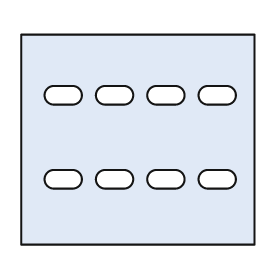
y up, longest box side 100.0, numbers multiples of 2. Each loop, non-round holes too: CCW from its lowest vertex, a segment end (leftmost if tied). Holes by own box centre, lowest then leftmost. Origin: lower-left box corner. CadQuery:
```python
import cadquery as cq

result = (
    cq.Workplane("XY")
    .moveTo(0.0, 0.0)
    .lineTo(100.0, 0.0)
    .lineTo(100.0, 90.0)
    .lineTo(0.0, 90.0)
    .close()
    .moveTo(14.0, 24.0)
    .lineTo(22.0, 24.0)
    .threePointArc((26.0, 28.0), (22.0, 32.0))
    .lineTo(14.0, 32.0)
    .threePointArc((10.0, 28.0), (14.0, 24.0))
    .close()
    .moveTo(36.0, 24.0)
    .lineTo(44.0, 24.0)
    .threePointArc((48.0, 28.0), (44.0, 32.0))
    .lineTo(36.0, 32.0)
    .threePointArc((32.0, 28.0), (36.0, 24.0))
    .close()
    .moveTo(58.0, 24.0)
    .lineTo(66.0, 24.0)
    .threePointArc((70.0, 28.0), (66.0, 32.0))
    .lineTo(58.0, 32.0)
    .threePointArc((54.0, 28.0), (58.0, 24.0))
    .close()
    .moveTo(80.0, 24.0)
    .lineTo(88.0, 24.0)
    .threePointArc((92.0, 28.0), (88.0, 32.0))
    .lineTo(80.0, 32.0)
    .threePointArc((76.0, 28.0), (80.0, 24.0))
    .close()
    .moveTo(14.0, 60.0)
    .lineTo(22.0, 60.0)
    .threePointArc((26.0, 64.0), (22.0, 68.0))
    .lineTo(14.0, 68.0)
    .threePointArc((10.0, 64.0), (14.0, 60.0))
    .close()
    .moveTo(36.0, 60.0)
    .lineTo(44.0, 60.0)
    .threePointArc((48.0, 64.0), (44.0, 68.0))
    .lineTo(36.0, 68.0)
    .threePointArc((32.0, 64.0), (36.0, 60.0))
    .close()
    .moveTo(58.0, 60.0)
    .lineTo(66.0, 60.0)
    .threePointArc((70.0, 64.0), (66.0, 68.0))
    .lineTo(58.0, 68.0)
    .threePointArc((54.0, 64.0), (58.0, 60.0))
    .close()
    .moveTo(80.0, 60.0)
    .lineTo(88.0, 60.0)
    .threePointArc((92.0, 64.0), (88.0, 68.0))
    .lineTo(80.0, 68.0)
    .threePointArc((76.0, 64.0), (80.0, 60.0))
    .close()
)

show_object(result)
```